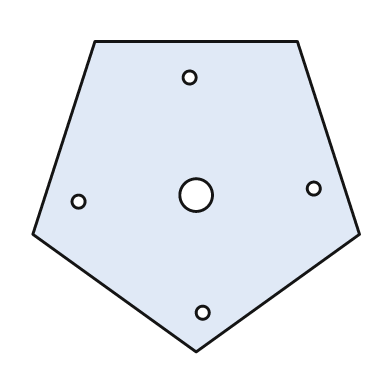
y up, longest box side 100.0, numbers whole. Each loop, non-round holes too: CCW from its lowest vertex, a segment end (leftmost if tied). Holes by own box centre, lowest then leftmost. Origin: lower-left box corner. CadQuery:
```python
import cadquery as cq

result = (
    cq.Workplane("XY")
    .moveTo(50.0, 0.0)
    .lineTo(100.0, 36.0)
    .lineTo(81.0, 95.0)
    .lineTo(19.0, 95.0)
    .lineTo(0.0, 36.0)
    .close()
    .moveTo(52.0, 12.0)
    .circle(2.0)
    .moveTo(14.0, 46.0)
    .circle(2.0)
    .moveTo(50.0, 48.0)
    .circle(5.0)
    .moveTo(86.0, 50.0)
    .circle(2.0)
    .moveTo(48.0, 84.0)
    .circle(2.0)
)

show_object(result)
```